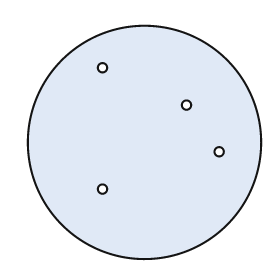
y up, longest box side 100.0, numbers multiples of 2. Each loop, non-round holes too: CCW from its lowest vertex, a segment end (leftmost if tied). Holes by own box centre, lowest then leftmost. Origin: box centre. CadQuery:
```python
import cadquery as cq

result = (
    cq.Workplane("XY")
    .moveTo(0.0, 0.0)
    .circle(50.0)
    .moveTo(-18.0, -20.0)
    .circle(2.0)
    .moveTo(32.0, -4.0)
    .circle(2.0)
    .moveTo(18.0, 16.0)
    .circle(2.0)
    .moveTo(-18.0, 32.0)
    .circle(2.0)
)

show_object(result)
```